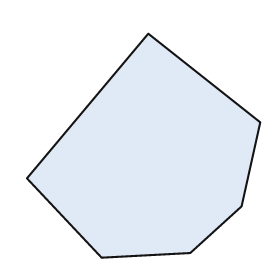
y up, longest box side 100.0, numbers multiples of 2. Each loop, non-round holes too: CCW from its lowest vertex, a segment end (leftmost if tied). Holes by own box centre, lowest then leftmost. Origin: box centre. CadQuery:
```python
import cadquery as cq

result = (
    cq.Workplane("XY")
    .moveTo(-18.0, -48.0)
    .lineTo(20.0, -46.0)
    .lineTo(42.0, -26.0)
    .lineTo(50.0, 10.0)
    .lineTo(2.0, 48.0)
    .lineTo(-50.0, -14.0)
    .close()
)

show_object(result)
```